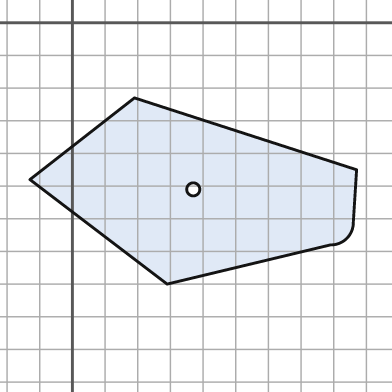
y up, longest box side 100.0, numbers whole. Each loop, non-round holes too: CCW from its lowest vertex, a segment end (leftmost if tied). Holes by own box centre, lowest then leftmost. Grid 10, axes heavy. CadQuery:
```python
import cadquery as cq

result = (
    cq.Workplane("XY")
    .moveTo(29.0, -80.0)
    .lineTo(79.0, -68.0)
    .threePointArc((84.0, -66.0), (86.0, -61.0))
    .lineTo(87.0, -45.0)
    .lineTo(19.0, -23.0)
    .lineTo(-13.0, -48.0)
    .close()
    .moveTo(37.0, -51.0)
    .circle(2.0)
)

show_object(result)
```